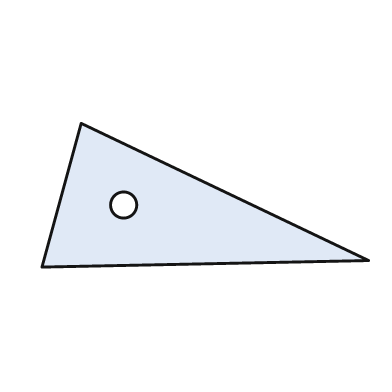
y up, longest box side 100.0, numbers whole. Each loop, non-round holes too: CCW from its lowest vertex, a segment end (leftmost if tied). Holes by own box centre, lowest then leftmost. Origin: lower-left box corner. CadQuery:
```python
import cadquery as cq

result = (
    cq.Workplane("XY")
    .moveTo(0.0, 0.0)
    .lineTo(100.0, 2.0)
    .lineTo(12.0, 44.0)
    .close()
    .moveTo(25.0, 19.0)
    .circle(4.0)
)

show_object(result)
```